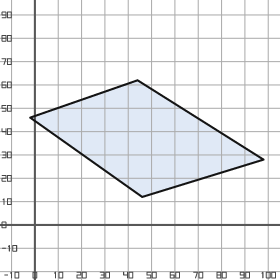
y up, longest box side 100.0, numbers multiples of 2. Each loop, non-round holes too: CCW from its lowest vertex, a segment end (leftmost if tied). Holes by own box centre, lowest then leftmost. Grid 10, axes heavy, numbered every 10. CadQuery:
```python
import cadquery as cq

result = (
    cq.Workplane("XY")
    .moveTo(46.0, 12.0)
    .lineTo(98.0, 28.0)
    .lineTo(44.0, 62.0)
    .lineTo(-2.0, 46.0)
    .close()
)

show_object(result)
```